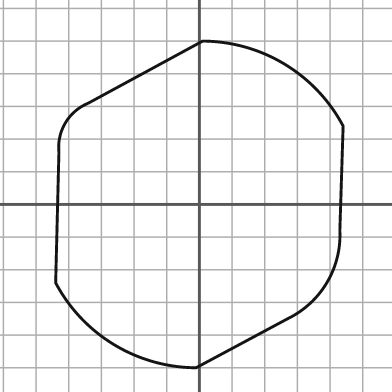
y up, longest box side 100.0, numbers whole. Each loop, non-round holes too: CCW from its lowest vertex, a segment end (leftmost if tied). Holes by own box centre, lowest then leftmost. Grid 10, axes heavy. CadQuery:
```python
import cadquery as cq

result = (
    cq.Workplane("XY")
    .moveTo(-1.0, -50.0)
    .lineTo(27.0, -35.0)
    .threePointArc((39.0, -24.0), (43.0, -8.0))
    .lineTo(44.0, 24.0)
    .threePointArc((26.0, 43.0), (1.0, 50.0))
    .lineTo(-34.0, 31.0)
    .threePointArc((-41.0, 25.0), (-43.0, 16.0))
    .lineTo(-44.0, -24.0)
    .threePointArc((-26.0, -43.0), (-1.0, -50.0))
    .close()
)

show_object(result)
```